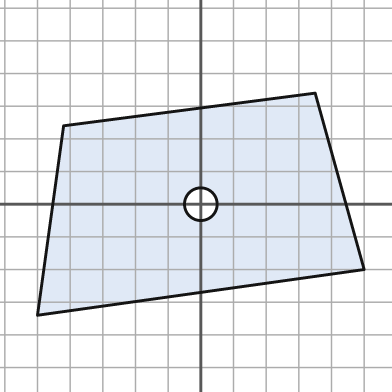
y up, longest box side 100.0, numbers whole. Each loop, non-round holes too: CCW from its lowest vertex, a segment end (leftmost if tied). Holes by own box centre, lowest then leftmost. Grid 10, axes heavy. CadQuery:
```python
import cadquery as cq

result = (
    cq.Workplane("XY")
    .moveTo(-50.0, -34.0)
    .lineTo(50.0, -20.0)
    .lineTo(35.0, 34.0)
    .lineTo(-42.0, 24.0)
    .close()
    .moveTo(0.0, 0.0)
    .circle(5.0)
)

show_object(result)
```